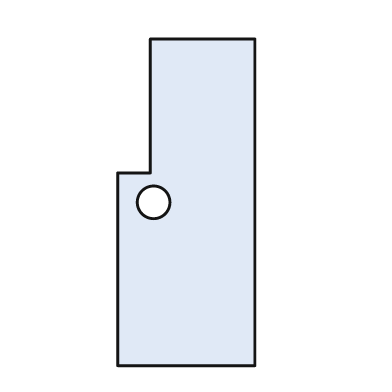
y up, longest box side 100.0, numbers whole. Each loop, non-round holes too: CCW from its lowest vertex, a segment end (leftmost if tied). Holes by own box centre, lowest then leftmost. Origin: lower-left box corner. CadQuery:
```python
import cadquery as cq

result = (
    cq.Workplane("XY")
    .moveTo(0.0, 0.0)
    .lineTo(42.0, 0.0)
    .lineTo(42.0, 100.0)
    .lineTo(10.0, 100.0)
    .lineTo(10.0, 59.0)
    .lineTo(0.0, 59.0)
    .close()
    .moveTo(11.0, 50.0)
    .circle(5.0)
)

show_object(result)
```